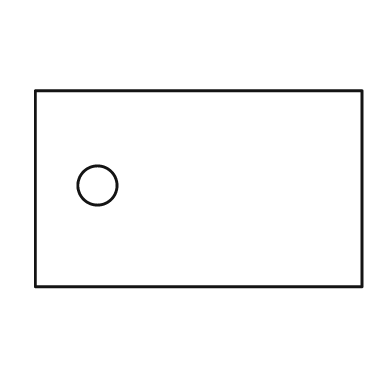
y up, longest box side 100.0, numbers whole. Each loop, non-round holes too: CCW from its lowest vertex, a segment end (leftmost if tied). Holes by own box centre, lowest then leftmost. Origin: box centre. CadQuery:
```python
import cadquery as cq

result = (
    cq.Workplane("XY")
    .moveTo(-50.0, -30.0)
    .lineTo(50.0, -30.0)
    .lineTo(50.0, 30.0)
    .lineTo(-50.0, 30.0)
    .close()
    .moveTo(-31.0, 1.0)
    .circle(6.0)
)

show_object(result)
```